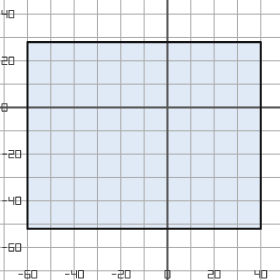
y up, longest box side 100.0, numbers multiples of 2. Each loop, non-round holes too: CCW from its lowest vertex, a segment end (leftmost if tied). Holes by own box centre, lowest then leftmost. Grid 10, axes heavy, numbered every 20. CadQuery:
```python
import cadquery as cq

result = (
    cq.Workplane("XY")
    .moveTo(-60.0, -52.0)
    .lineTo(40.0, -52.0)
    .lineTo(40.0, 28.0)
    .lineTo(-60.0, 28.0)
    .close()
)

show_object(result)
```